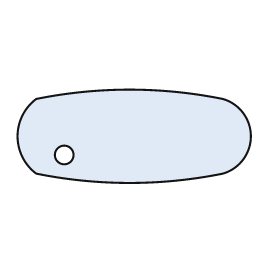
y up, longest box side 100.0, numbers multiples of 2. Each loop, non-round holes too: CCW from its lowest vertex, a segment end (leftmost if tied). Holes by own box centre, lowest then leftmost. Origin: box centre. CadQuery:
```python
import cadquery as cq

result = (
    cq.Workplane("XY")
    .moveTo(-42.0, -16.0)
    .threePointArc((-2.0, -20.0), (38.0, -16.0))
    .threePointArc((50.0, 0.0), (38.0, 16.0))
    .threePointArc((-2.0, 20.0), (-42.0, 16.0))
    .threePointArc((-50.0, 0.0), (-42.0, -16.0))
    .close()
    .moveTo(-30.0, -8.0)
    .circle(4.0)
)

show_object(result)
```